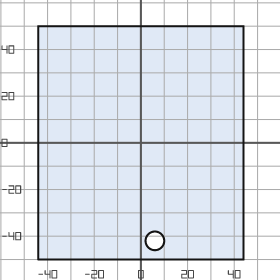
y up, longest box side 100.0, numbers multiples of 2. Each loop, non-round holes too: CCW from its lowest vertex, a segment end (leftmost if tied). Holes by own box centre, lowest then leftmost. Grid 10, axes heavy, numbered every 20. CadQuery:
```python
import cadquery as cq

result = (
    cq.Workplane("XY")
    .moveTo(-44.0, -50.0)
    .lineTo(44.0, -50.0)
    .lineTo(44.0, 50.0)
    .lineTo(-44.0, 50.0)
    .close()
    .moveTo(6.0, -42.0)
    .circle(4.0)
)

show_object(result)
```